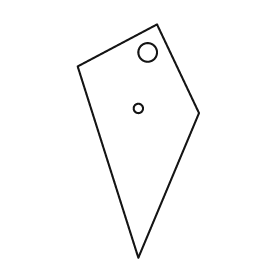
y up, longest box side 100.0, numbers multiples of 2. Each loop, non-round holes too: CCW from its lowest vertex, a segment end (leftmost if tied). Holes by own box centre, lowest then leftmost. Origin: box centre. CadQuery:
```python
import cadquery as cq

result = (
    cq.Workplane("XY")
    .moveTo(0.0, -50.0)
    .lineTo(26.0, 12.0)
    .lineTo(8.0, 50.0)
    .lineTo(-26.0, 32.0)
    .close()
    .moveTo(0.0, 14.0)
    .circle(2.0)
    .moveTo(4.0, 38.0)
    .circle(4.0)
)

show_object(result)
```